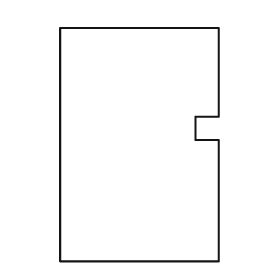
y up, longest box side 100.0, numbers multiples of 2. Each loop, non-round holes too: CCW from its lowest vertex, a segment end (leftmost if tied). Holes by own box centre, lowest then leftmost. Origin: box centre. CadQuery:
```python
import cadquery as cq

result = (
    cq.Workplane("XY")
    .moveTo(-34.0, -50.0)
    .lineTo(34.0, -50.0)
    .lineTo(34.0, 2.0)
    .lineTo(24.0, 2.0)
    .lineTo(24.0, 12.0)
    .lineTo(34.0, 12.0)
    .lineTo(34.0, 50.0)
    .lineTo(-34.0, 50.0)
    .close()
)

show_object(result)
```